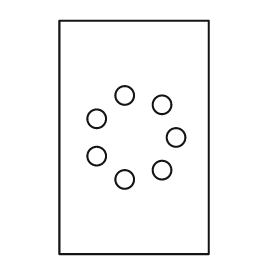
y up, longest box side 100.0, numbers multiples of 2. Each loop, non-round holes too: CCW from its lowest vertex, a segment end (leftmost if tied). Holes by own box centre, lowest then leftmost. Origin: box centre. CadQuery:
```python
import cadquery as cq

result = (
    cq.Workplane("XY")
    .moveTo(-32.0, -50.0)
    .lineTo(32.0, -50.0)
    .lineTo(32.0, 50.0)
    .lineTo(-32.0, 50.0)
    .close()
    .moveTo(-4.0, -18.0)
    .circle(4.0)
    .moveTo(12.0, -14.0)
    .circle(4.0)
    .moveTo(-16.0, -8.0)
    .circle(4.0)
    .moveTo(18.0, 0.0)
    .circle(4.0)
    .moveTo(-16.0, 8.0)
    .circle(4.0)
    .moveTo(12.0, 14.0)
    .circle(4.0)
    .moveTo(-4.0, 18.0)
    .circle(4.0)
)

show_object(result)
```